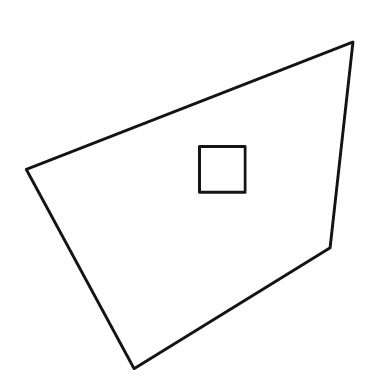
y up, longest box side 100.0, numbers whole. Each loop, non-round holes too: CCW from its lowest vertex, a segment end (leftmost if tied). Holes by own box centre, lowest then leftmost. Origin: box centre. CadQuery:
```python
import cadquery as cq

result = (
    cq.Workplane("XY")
    .moveTo(-17.0, -50.0)
    .lineTo(43.0, -13.0)
    .lineTo(50.0, 50.0)
    .lineTo(-50.0, 11.0)
    .close()
    .moveTo(3.0, 4.0)
    .lineTo(17.0, 4.0)
    .lineTo(17.0, 18.0)
    .lineTo(3.0, 18.0)
    .close()
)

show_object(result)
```